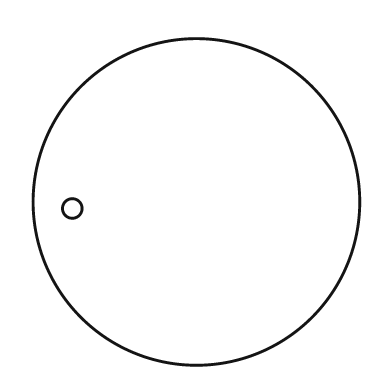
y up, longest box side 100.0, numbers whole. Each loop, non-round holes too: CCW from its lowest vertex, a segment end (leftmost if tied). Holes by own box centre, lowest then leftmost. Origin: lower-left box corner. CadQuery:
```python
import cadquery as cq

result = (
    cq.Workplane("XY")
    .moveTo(50.0, 50.0)
    .circle(50.0)
    .moveTo(12.0, 48.0)
    .circle(3.0)
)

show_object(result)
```